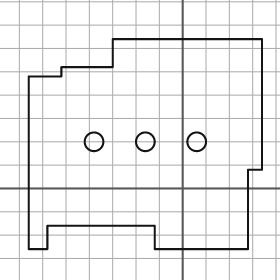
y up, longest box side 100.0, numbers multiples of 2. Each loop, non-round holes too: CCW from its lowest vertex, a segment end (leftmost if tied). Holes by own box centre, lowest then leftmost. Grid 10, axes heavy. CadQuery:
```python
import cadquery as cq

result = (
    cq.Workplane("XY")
    .moveTo(-66.0, -26.0)
    .lineTo(-58.0, -26.0)
    .lineTo(-58.0, -16.0)
    .lineTo(-12.0, -16.0)
    .lineTo(-12.0, -26.0)
    .lineTo(28.0, -26.0)
    .lineTo(28.0, 8.0)
    .lineTo(34.0, 8.0)
    .lineTo(34.0, 64.0)
    .lineTo(-30.0, 64.0)
    .lineTo(-30.0, 52.0)
    .lineTo(-52.0, 52.0)
    .lineTo(-52.0, 48.0)
    .lineTo(-66.0, 48.0)
    .close()
    .moveTo(-38.0, 20.0)
    .circle(4.0)
    .moveTo(-16.0, 20.0)
    .circle(4.0)
    .moveTo(6.0, 20.0)
    .circle(4.0)
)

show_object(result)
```